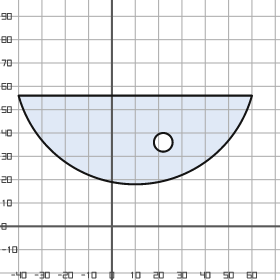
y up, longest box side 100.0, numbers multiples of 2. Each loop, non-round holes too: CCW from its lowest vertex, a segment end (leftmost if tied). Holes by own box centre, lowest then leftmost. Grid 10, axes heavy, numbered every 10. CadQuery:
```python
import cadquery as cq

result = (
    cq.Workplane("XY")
    .moveTo(-40.0, 56.0)
    .threePointArc((10.0, 18.0), (60.0, 56.0))
    .close()
    .moveTo(22.0, 36.0)
    .circle(4.0)
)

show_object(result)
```